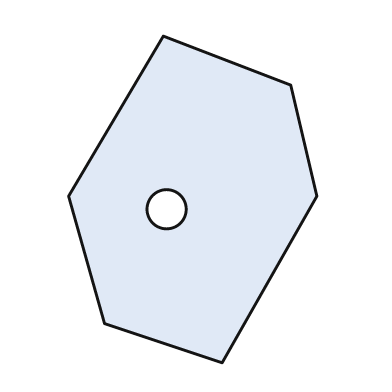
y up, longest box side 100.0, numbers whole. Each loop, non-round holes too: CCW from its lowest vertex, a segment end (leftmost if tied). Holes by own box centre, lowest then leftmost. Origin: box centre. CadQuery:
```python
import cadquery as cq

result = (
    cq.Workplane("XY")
    .moveTo(9.0, -50.0)
    .lineTo(38.0, 1.0)
    .lineTo(30.0, 35.0)
    .lineTo(-9.0, 50.0)
    .lineTo(-38.0, 1.0)
    .lineTo(-27.0, -38.0)
    .close()
    .moveTo(-8.0, -3.0)
    .circle(6.0)
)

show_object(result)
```